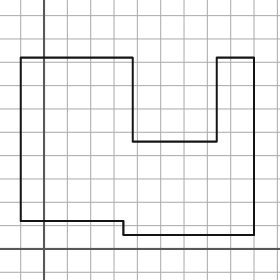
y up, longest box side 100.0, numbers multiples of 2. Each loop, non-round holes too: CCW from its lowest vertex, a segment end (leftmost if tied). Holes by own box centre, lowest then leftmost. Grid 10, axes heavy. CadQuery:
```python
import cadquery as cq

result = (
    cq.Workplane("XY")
    .moveTo(34.0, 6.0)
    .lineTo(90.0, 6.0)
    .lineTo(90.0, 82.0)
    .lineTo(74.0, 82.0)
    .lineTo(74.0, 46.0)
    .lineTo(38.0, 46.0)
    .lineTo(38.0, 82.0)
    .lineTo(-10.0, 82.0)
    .lineTo(-10.0, 12.0)
    .lineTo(34.0, 12.0)
    .close()
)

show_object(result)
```